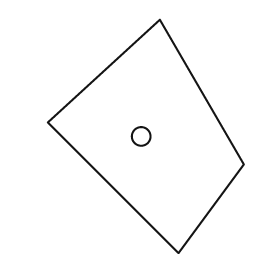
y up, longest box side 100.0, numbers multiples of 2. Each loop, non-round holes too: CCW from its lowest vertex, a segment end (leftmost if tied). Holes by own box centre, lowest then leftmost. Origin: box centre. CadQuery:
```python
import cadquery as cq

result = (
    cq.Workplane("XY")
    .moveTo(14.0, -50.0)
    .lineTo(42.0, -12.0)
    .lineTo(6.0, 50.0)
    .lineTo(-42.0, 6.0)
    .close()
    .moveTo(-2.0, 0.0)
    .circle(4.0)
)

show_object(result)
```